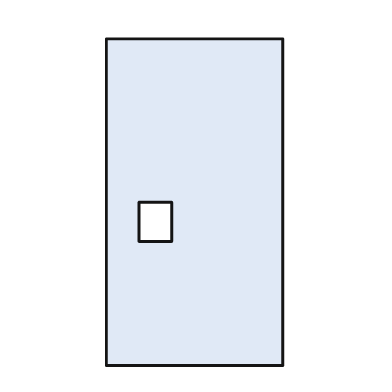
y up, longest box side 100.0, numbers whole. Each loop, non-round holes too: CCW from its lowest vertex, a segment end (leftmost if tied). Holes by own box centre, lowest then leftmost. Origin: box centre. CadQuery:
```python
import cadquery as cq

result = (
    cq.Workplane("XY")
    .moveTo(-27.0, -50.0)
    .lineTo(27.0, -50.0)
    .lineTo(27.0, 50.0)
    .lineTo(-27.0, 50.0)
    .close()
    .moveTo(-17.0, -12.0)
    .lineTo(-7.0, -12.0)
    .lineTo(-7.0, 0.0)
    .lineTo(-17.0, 0.0)
    .close()
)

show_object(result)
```